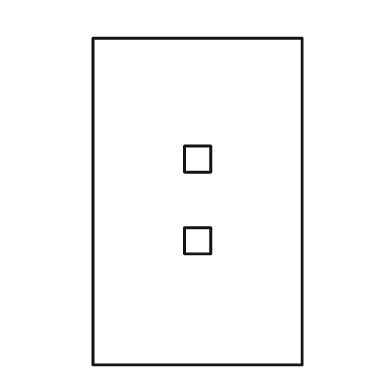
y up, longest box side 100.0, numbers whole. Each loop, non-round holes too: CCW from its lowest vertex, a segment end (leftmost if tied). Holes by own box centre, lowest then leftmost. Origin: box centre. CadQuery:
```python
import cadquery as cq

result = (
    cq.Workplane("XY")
    .moveTo(-32.0, -50.0)
    .lineTo(32.0, -50.0)
    .lineTo(32.0, 50.0)
    .lineTo(-32.0, 50.0)
    .close()
    .moveTo(-4.0, -16.0)
    .lineTo(4.0, -16.0)
    .lineTo(4.0, -8.0)
    .lineTo(-4.0, -8.0)
    .close()
    .moveTo(-4.0, 9.0)
    .lineTo(4.0, 9.0)
    .lineTo(4.0, 17.0)
    .lineTo(-4.0, 17.0)
    .close()
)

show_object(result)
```